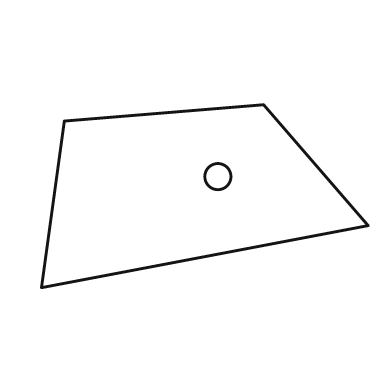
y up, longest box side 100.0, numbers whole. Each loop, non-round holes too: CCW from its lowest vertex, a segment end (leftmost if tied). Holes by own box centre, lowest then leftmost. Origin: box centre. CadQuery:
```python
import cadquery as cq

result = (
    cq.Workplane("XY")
    .moveTo(-50.0, -28.0)
    .lineTo(50.0, -9.0)
    .lineTo(18.0, 28.0)
    .lineTo(-43.0, 23.0)
    .close()
    .moveTo(4.0, 6.0)
    .circle(4.0)
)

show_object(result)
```